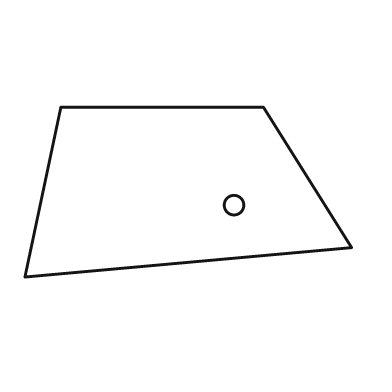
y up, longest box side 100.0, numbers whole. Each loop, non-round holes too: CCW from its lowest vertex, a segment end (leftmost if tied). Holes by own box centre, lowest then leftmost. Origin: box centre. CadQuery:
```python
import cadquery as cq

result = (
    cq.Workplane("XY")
    .moveTo(-50.0, -26.0)
    .lineTo(50.0, -17.0)
    .lineTo(23.0, 26.0)
    .lineTo(-39.0, 26.0)
    .close()
    .moveTo(14.0, -4.0)
    .circle(3.0)
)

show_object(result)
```